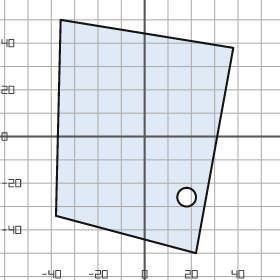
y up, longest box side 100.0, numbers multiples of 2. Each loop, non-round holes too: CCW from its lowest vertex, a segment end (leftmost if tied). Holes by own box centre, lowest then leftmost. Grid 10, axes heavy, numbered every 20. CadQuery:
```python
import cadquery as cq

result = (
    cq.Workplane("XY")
    .moveTo(22.0, -50.0)
    .lineTo(38.0, 38.0)
    .lineTo(-36.0, 50.0)
    .lineTo(-38.0, -34.0)
    .close()
    .moveTo(18.0, -26.0)
    .circle(4.0)
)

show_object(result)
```